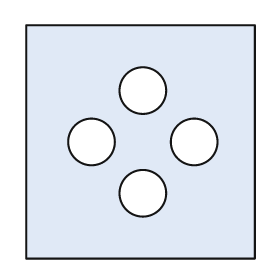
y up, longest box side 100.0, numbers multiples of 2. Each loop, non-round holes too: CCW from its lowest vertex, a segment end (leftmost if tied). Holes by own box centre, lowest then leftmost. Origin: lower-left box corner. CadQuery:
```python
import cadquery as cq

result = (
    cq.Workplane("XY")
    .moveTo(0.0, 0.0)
    .lineTo(98.0, 0.0)
    .lineTo(98.0, 100.0)
    .lineTo(0.0, 100.0)
    .close()
    .moveTo(50.0, 28.0)
    .circle(10.0)
    .moveTo(28.0, 50.0)
    .circle(10.0)
    .moveTo(72.0, 50.0)
    .circle(10.0)
    .moveTo(50.0, 72.0)
    .circle(10.0)
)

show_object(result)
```